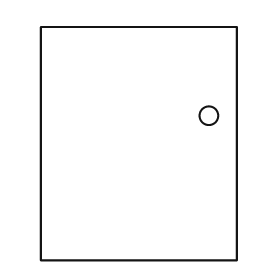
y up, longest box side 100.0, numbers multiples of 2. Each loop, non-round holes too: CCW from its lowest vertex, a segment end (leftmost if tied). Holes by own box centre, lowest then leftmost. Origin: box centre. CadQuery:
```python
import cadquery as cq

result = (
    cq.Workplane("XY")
    .moveTo(-42.0, -50.0)
    .lineTo(42.0, -50.0)
    .lineTo(42.0, 50.0)
    .lineTo(-42.0, 50.0)
    .close()
    .moveTo(30.0, 12.0)
    .circle(4.0)
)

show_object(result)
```